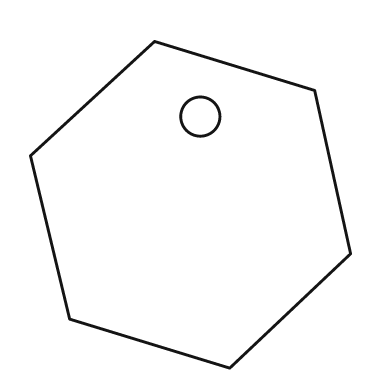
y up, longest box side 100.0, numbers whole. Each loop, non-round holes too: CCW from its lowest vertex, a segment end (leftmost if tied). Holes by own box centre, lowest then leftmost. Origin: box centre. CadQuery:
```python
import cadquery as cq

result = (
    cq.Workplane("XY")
    .moveTo(12.0, -50.0)
    .lineTo(49.0, -15.0)
    .lineTo(38.0, 35.0)
    .lineTo(-11.0, 50.0)
    .lineTo(-49.0, 15.0)
    .lineTo(-37.0, -35.0)
    .close()
    .moveTo(3.0, 27.0)
    .circle(6.0)
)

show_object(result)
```